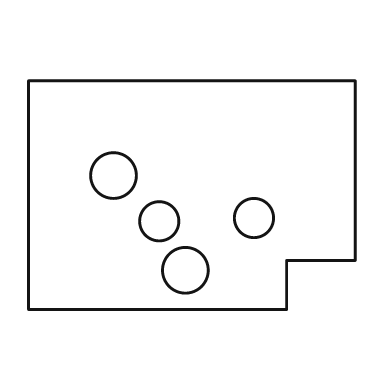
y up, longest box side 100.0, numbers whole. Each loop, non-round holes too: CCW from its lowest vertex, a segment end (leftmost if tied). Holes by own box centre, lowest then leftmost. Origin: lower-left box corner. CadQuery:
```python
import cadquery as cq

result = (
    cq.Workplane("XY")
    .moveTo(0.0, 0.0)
    .lineTo(79.0, 0.0)
    .lineTo(79.0, 15.0)
    .lineTo(100.0, 15.0)
    .lineTo(100.0, 70.0)
    .lineTo(0.0, 70.0)
    .close()
    .moveTo(48.0, 12.0)
    .circle(7.0)
    .moveTo(40.0, 27.0)
    .circle(6.0)
    .moveTo(69.0, 28.0)
    .circle(6.0)
    .moveTo(26.0, 41.0)
    .circle(7.0)
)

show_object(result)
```